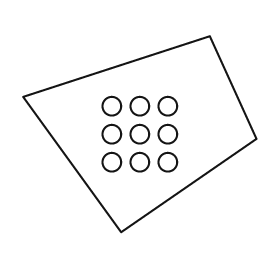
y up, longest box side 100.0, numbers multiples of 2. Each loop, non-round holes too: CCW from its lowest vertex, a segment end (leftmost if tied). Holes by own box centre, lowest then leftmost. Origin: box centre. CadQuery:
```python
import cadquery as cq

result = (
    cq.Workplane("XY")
    .moveTo(-8.0, -42.0)
    .lineTo(50.0, -2.0)
    .lineTo(30.0, 42.0)
    .lineTo(-50.0, 16.0)
    .close()
    .moveTo(-12.0, -12.0)
    .circle(4.0)
    .moveTo(0.0, -12.0)
    .circle(4.0)
    .moveTo(12.0, -12.0)
    .circle(4.0)
    .moveTo(-12.0, 0.0)
    .circle(4.0)
    .moveTo(0.0, 0.0)
    .circle(4.0)
    .moveTo(12.0, 0.0)
    .circle(4.0)
    .moveTo(-12.0, 12.0)
    .circle(4.0)
    .moveTo(0.0, 12.0)
    .circle(4.0)
    .moveTo(12.0, 12.0)
    .circle(4.0)
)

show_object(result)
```